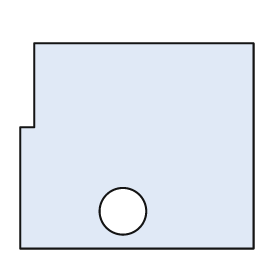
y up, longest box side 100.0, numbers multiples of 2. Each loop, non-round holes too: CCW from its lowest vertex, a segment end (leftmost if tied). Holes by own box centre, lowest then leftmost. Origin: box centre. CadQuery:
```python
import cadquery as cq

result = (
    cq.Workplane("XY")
    .moveTo(-50.0, -44.0)
    .lineTo(50.0, -44.0)
    .lineTo(50.0, 44.0)
    .lineTo(-44.0, 44.0)
    .lineTo(-44.0, 8.0)
    .lineTo(-50.0, 8.0)
    .close()
    .moveTo(-6.0, -28.0)
    .circle(10.0)
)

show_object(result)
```